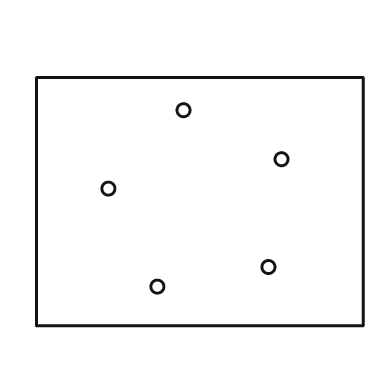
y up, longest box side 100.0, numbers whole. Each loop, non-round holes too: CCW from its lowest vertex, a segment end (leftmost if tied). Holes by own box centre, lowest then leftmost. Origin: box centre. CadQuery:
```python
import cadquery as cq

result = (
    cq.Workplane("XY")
    .moveTo(-50.0, -38.0)
    .lineTo(50.0, -38.0)
    .lineTo(50.0, 38.0)
    .lineTo(-50.0, 38.0)
    .close()
    .moveTo(-13.0, -26.0)
    .circle(2.0)
    .moveTo(21.0, -20.0)
    .circle(2.0)
    .moveTo(-28.0, 4.0)
    .circle(2.0)
    .moveTo(25.0, 13.0)
    .circle(2.0)
    .moveTo(-5.0, 28.0)
    .circle(2.0)
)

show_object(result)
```